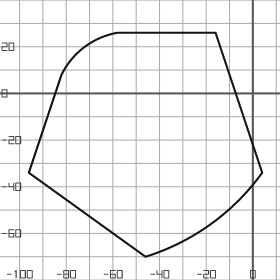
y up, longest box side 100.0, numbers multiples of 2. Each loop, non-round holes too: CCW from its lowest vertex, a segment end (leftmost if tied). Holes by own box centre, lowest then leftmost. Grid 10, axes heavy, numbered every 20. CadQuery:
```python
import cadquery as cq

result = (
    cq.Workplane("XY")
    .moveTo(-46.0, -70.0)
    .threePointArc((-18.0, -56.0), (4.0, -34.0))
    .lineTo(-16.0, 26.0)
    .lineTo(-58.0, 26.0)
    .threePointArc((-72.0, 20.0), (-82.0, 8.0))
    .lineTo(-96.0, -34.0)
    .close()
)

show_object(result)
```